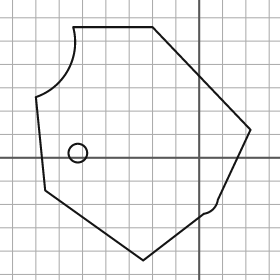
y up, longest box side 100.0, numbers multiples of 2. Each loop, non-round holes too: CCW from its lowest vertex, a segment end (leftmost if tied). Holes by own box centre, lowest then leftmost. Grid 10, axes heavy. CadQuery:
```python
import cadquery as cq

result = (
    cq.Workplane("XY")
    .moveTo(-24.0, -44.0)
    .lineTo(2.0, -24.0)
    .threePointArc((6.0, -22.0), (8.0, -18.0))
    .lineTo(22.0, 12.0)
    .lineTo(-20.0, 56.0)
    .lineTo(-54.0, 56.0)
    .threePointArc((-56.0, 38.0), (-70.0, 26.0))
    .lineTo(-66.0, -14.0)
    .close()
    .moveTo(-52.0, 2.0)
    .circle(4.0)
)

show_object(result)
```